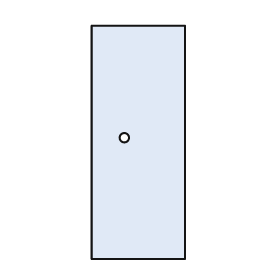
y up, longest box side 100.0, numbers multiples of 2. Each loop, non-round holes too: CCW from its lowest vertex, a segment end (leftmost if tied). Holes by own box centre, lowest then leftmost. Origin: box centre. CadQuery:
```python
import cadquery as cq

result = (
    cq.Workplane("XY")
    .moveTo(-20.0, -50.0)
    .lineTo(20.0, -50.0)
    .lineTo(20.0, 50.0)
    .lineTo(-20.0, 50.0)
    .close()
    .moveTo(-6.0, 2.0)
    .circle(2.0)
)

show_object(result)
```